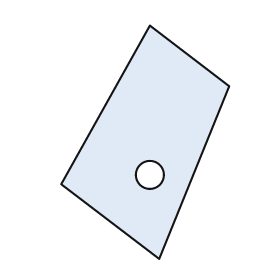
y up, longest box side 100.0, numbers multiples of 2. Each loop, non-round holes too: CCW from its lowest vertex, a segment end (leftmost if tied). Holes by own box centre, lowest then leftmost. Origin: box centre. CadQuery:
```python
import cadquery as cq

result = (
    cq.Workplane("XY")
    .moveTo(6.0, -50.0)
    .lineTo(36.0, 24.0)
    .lineTo(2.0, 50.0)
    .lineTo(-36.0, -18.0)
    .close()
    .moveTo(2.0, -14.0)
    .circle(6.0)
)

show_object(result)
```